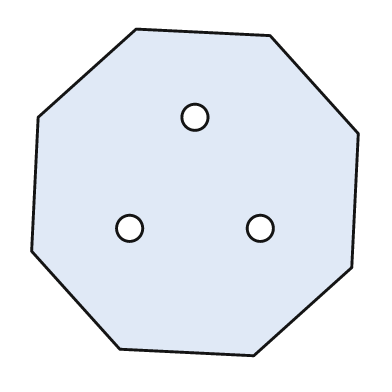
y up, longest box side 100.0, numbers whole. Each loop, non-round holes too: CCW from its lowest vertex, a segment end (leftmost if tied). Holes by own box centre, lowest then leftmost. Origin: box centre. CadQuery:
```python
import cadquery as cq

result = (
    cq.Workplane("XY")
    .moveTo(18.0, -50.0)
    .lineTo(48.0, -23.0)
    .lineTo(50.0, 18.0)
    .lineTo(23.0, 48.0)
    .lineTo(-18.0, 50.0)
    .lineTo(-48.0, 23.0)
    .lineTo(-50.0, -18.0)
    .lineTo(-23.0, -48.0)
    .close()
    .moveTo(-20.0, -11.0)
    .circle(4.0)
    .moveTo(20.0, -11.0)
    .circle(4.0)
    .moveTo(0.0, 23.0)
    .circle(4.0)
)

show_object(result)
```